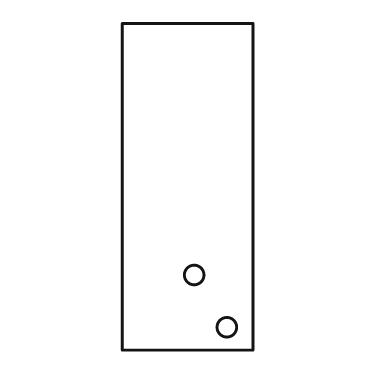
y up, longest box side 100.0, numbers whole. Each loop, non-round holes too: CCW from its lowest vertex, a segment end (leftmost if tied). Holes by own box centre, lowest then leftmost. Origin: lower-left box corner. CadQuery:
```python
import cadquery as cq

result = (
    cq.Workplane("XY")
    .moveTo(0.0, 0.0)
    .lineTo(40.0, 0.0)
    .lineTo(40.0, 100.0)
    .lineTo(0.0, 100.0)
    .close()
    .moveTo(32.0, 7.0)
    .circle(3.0)
    .moveTo(22.0, 23.0)
    .circle(3.0)
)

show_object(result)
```